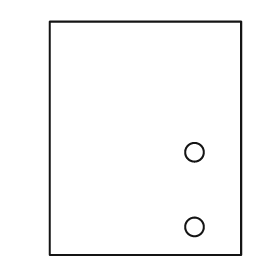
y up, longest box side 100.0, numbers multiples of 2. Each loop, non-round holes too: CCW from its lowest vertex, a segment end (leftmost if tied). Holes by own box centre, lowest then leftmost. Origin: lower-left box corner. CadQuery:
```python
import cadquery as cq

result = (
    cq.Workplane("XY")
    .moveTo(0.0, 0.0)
    .lineTo(82.0, 0.0)
    .lineTo(82.0, 100.0)
    .lineTo(0.0, 100.0)
    .close()
    .moveTo(62.0, 12.0)
    .circle(4.0)
    .moveTo(62.0, 44.0)
    .circle(4.0)
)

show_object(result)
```